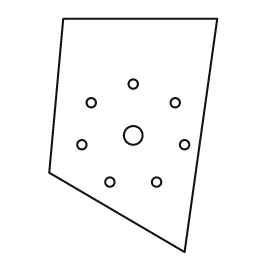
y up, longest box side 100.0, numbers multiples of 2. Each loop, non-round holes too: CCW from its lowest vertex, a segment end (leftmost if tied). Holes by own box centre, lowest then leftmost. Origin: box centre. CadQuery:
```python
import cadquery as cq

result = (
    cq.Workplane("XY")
    .moveTo(22.0, -50.0)
    .lineTo(36.0, 50.0)
    .lineTo(-30.0, 50.0)
    .lineTo(-36.0, -16.0)
    .close()
    .moveTo(-10.0, -20.0)
    .circle(2.0)
    .moveTo(10.0, -20.0)
    .circle(2.0)
    .moveTo(-22.0, -4.0)
    .circle(2.0)
    .moveTo(22.0, -4.0)
    .circle(2.0)
    .moveTo(0.0, 0.0)
    .circle(4.0)
    .moveTo(-18.0, 14.0)
    .circle(2.0)
    .moveTo(18.0, 14.0)
    .circle(2.0)
    .moveTo(0.0, 22.0)
    .circle(2.0)
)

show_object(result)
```